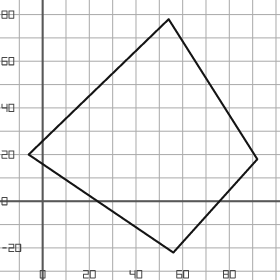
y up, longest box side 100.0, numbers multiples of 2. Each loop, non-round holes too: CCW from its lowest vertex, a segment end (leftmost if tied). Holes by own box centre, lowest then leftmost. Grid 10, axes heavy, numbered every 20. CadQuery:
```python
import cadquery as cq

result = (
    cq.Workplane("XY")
    .moveTo(56.0, -22.0)
    .lineTo(92.0, 18.0)
    .lineTo(54.0, 78.0)
    .lineTo(-6.0, 20.0)
    .close()
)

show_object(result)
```